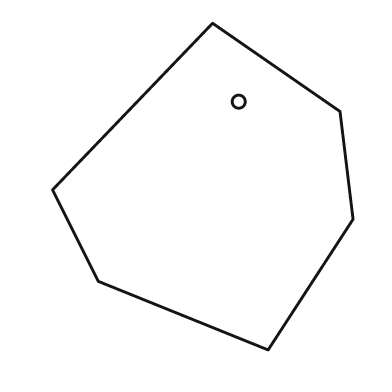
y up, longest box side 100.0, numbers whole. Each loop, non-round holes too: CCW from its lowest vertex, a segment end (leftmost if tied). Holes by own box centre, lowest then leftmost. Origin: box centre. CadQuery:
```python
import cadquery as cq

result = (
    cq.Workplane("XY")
    .moveTo(20.0, -50.0)
    .lineTo(46.0, -10.0)
    .lineTo(42.0, 23.0)
    .lineTo(3.0, 50.0)
    .lineTo(-46.0, -1.0)
    .lineTo(-32.0, -29.0)
    .close()
    .moveTo(11.0, 26.0)
    .circle(2.0)
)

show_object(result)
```